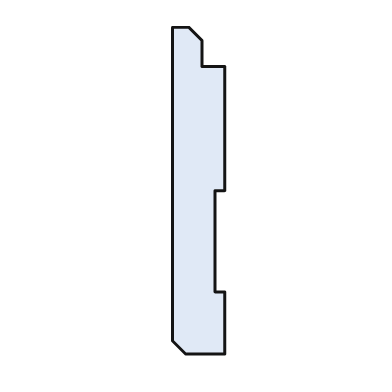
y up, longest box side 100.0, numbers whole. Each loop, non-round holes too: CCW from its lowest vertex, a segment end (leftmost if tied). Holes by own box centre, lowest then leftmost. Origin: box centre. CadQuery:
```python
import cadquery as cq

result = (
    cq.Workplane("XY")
    .moveTo(-4.0, -50.0)
    .lineTo(8.0, -50.0)
    .lineTo(8.0, -31.0)
    .lineTo(5.0, -31.0)
    .lineTo(5.0, 0.0)
    .lineTo(8.0, 0.0)
    .lineTo(8.0, 38.0)
    .lineTo(1.0, 38.0)
    .lineTo(1.0, 46.0)
    .lineTo(-3.0, 50.0)
    .lineTo(-8.0, 50.0)
    .lineTo(-8.0, -46.0)
    .close()
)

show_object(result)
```